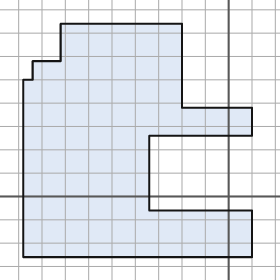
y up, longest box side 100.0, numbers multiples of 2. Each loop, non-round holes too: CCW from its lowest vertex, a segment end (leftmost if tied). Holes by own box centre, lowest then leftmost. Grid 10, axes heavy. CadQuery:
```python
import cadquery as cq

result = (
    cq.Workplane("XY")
    .moveTo(-88.0, -26.0)
    .lineTo(10.0, -26.0)
    .lineTo(10.0, -6.0)
    .lineTo(-34.0, -6.0)
    .lineTo(-34.0, 26.0)
    .lineTo(10.0, 26.0)
    .lineTo(10.0, 38.0)
    .lineTo(-20.0, 38.0)
    .lineTo(-20.0, 74.0)
    .lineTo(-72.0, 74.0)
    .lineTo(-72.0, 58.0)
    .lineTo(-84.0, 58.0)
    .lineTo(-84.0, 50.0)
    .lineTo(-88.0, 50.0)
    .close()
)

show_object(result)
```